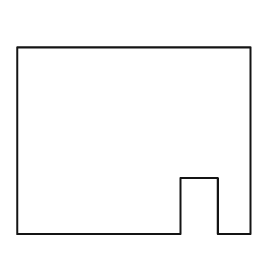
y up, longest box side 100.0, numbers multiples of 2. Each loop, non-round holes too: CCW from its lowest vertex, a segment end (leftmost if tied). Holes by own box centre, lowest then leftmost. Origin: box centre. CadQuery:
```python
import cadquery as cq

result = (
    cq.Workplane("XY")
    .moveTo(-50.0, -40.0)
    .lineTo(20.0, -40.0)
    .lineTo(20.0, -16.0)
    .lineTo(36.0, -16.0)
    .lineTo(36.0, -40.0)
    .lineTo(50.0, -40.0)
    .lineTo(50.0, 40.0)
    .lineTo(-50.0, 40.0)
    .close()
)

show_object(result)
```